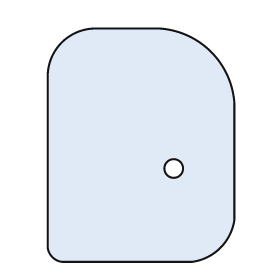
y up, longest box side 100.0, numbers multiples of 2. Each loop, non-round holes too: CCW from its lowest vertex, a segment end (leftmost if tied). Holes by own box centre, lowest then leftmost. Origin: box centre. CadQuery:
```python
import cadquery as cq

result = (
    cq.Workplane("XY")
    .moveTo(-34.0, -50.0)
    .lineTo(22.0, -50.0)
    .threePointArc((34.0, -44.0), (40.0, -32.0))
    .lineTo(40.0, 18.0)
    .threePointArc((30.0, 40.0), (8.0, 50.0))
    .lineTo(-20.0, 50.0)
    .threePointArc((-34.0, 44.0), (-40.0, 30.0))
    .lineTo(-40.0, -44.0)
    .threePointArc((-38.0, -48.0), (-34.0, -50.0))
    .close()
    .moveTo(14.0, -10.0)
    .circle(4.0)
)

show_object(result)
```